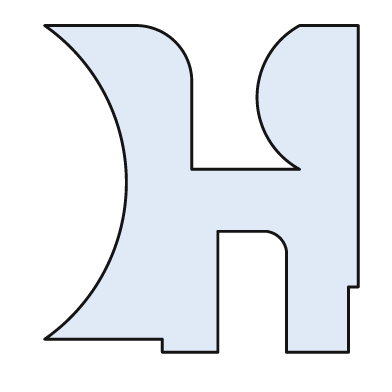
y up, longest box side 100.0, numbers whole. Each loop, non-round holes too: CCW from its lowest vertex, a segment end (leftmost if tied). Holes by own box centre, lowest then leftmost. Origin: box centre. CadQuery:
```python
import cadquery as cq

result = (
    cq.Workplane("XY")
    .moveTo(-12.0, -50.0)
    .lineTo(5.0, -50.0)
    .lineTo(5.0, -13.0)
    .lineTo(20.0, -13.0)
    .threePointArc((24.0, -15.0), (26.0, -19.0))
    .lineTo(26.0, -50.0)
    .lineTo(45.0, -50.0)
    .lineTo(45.0, -30.0)
    .lineTo(48.0, -30.0)
    .lineTo(48.0, 50.0)
    .lineTo(30.0, 50.0)
    .threePointArc((17.0, 28.0), (30.0, 6.0))
    .lineTo(-3.0, 6.0)
    .lineTo(-3.0, 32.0)
    .threePointArc((-8.0, 45.0), (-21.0, 50.0))
    .lineTo(-48.0, 50.0)
    .threePointArc((-23.0, 2.0), (-48.0, -46.0))
    .lineTo(-12.0, -46.0)
    .close()
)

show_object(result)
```